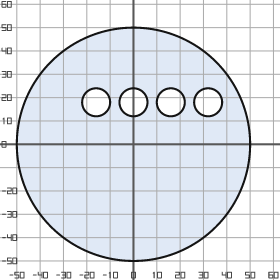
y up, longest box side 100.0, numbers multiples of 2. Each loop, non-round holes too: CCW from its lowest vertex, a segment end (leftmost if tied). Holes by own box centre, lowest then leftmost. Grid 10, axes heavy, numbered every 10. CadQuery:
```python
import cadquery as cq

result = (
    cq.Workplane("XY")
    .moveTo(0.0, 0.0)
    .circle(50.0)
    .moveTo(-16.0, 18.0)
    .circle(6.0)
    .moveTo(0.0, 18.0)
    .circle(6.0)
    .moveTo(16.0, 18.0)
    .circle(6.0)
    .moveTo(32.0, 18.0)
    .circle(6.0)
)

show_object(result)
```